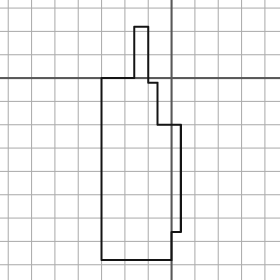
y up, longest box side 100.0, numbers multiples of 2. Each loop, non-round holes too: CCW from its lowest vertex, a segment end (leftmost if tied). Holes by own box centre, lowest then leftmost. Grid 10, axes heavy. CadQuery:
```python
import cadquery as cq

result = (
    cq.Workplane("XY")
    .moveTo(-30.0, -78.0)
    .lineTo(0.0, -78.0)
    .lineTo(0.0, -66.0)
    .lineTo(4.0, -66.0)
    .lineTo(4.0, -20.0)
    .lineTo(-6.0, -20.0)
    .lineTo(-6.0, -2.0)
    .lineTo(-10.0, -2.0)
    .lineTo(-10.0, 22.0)
    .lineTo(-16.0, 22.0)
    .lineTo(-16.0, 0.0)
    .lineTo(-30.0, 0.0)
    .close()
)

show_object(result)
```